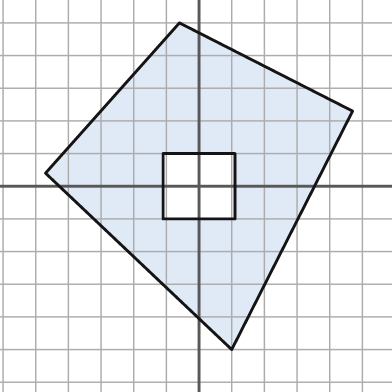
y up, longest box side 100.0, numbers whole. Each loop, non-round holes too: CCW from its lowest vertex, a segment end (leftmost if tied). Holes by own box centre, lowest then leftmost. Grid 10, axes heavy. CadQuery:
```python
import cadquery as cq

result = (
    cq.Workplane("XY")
    .moveTo(10.0, -50.0)
    .lineTo(47.0, 23.0)
    .lineTo(-6.0, 50.0)
    .lineTo(-47.0, 4.0)
    .close()
    .moveTo(-11.0, -10.0)
    .lineTo(11.0, -10.0)
    .lineTo(11.0, 10.0)
    .lineTo(-11.0, 10.0)
    .close()
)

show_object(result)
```